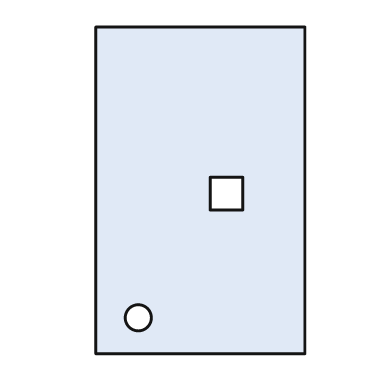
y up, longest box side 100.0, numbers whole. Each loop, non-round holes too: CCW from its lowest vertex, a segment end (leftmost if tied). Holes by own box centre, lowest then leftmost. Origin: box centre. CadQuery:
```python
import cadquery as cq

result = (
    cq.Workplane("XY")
    .moveTo(-32.0, -50.0)
    .lineTo(32.0, -50.0)
    .lineTo(32.0, 50.0)
    .lineTo(-32.0, 50.0)
    .close()
    .moveTo(-19.0, -39.0)
    .circle(4.0)
    .moveTo(3.0, -6.0)
    .lineTo(13.0, -6.0)
    .lineTo(13.0, 4.0)
    .lineTo(3.0, 4.0)
    .close()
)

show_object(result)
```